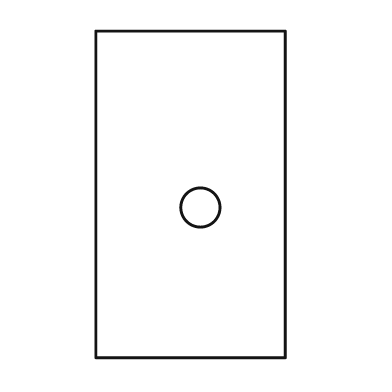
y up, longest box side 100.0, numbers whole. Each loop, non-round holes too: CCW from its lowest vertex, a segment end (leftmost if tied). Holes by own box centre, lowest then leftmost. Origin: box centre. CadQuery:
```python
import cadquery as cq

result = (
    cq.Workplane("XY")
    .moveTo(-29.0, -50.0)
    .lineTo(29.0, -50.0)
    .lineTo(29.0, 50.0)
    .lineTo(-29.0, 50.0)
    .close()
    .moveTo(3.0, -4.0)
    .circle(6.0)
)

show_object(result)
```